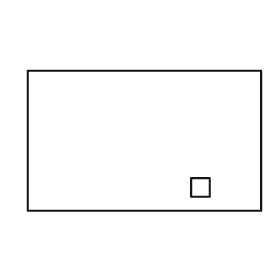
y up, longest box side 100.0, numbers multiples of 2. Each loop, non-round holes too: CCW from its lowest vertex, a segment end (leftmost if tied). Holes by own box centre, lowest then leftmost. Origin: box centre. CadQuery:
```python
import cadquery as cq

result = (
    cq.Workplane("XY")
    .moveTo(-50.0, -30.0)
    .lineTo(50.0, -30.0)
    .lineTo(50.0, 30.0)
    .lineTo(-50.0, 30.0)
    .close()
    .moveTo(20.0, -24.0)
    .lineTo(28.0, -24.0)
    .lineTo(28.0, -16.0)
    .lineTo(20.0, -16.0)
    .close()
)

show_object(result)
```